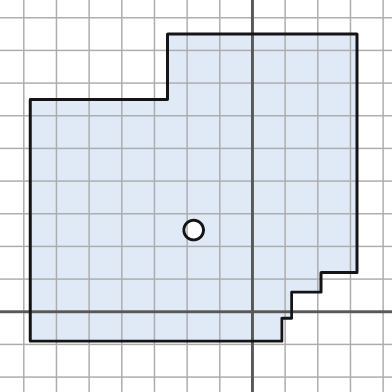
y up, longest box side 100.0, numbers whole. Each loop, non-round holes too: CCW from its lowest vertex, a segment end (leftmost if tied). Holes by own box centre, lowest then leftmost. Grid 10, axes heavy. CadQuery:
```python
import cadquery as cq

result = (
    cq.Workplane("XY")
    .moveTo(-68.0, -9.0)
    .lineTo(9.0, -9.0)
    .lineTo(9.0, -2.0)
    .lineTo(12.0, -2.0)
    .lineTo(12.0, 6.0)
    .lineTo(21.0, 6.0)
    .lineTo(21.0, 12.0)
    .lineTo(32.0, 12.0)
    .lineTo(32.0, 85.0)
    .lineTo(-26.0, 85.0)
    .lineTo(-26.0, 65.0)
    .lineTo(-68.0, 65.0)
    .close()
    .moveTo(-18.0, 25.0)
    .circle(3.0)
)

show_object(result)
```